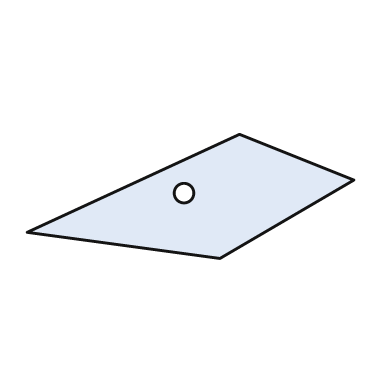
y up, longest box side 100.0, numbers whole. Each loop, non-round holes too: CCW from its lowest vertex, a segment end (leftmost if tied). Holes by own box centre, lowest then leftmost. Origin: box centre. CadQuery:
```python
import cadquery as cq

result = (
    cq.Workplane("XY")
    .moveTo(9.0, -19.0)
    .lineTo(50.0, 5.0)
    .lineTo(15.0, 19.0)
    .lineTo(-50.0, -11.0)
    .close()
    .moveTo(-2.0, 1.0)
    .circle(3.0)
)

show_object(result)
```